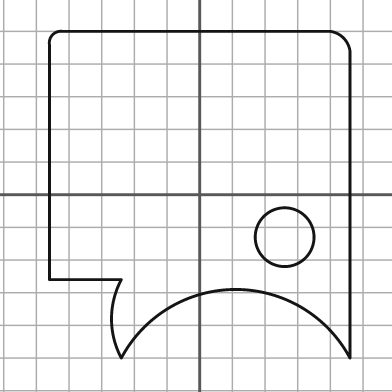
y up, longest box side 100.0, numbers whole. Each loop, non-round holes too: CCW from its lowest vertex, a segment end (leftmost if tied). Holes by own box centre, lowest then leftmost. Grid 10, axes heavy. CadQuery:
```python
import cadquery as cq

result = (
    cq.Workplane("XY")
    .moveTo(-24.0, -50.0)
    .threePointArc((11.0, -29.0), (46.0, -50.0))
    .lineTo(46.0, 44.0)
    .threePointArc((44.0, 48.0), (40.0, 50.0))
    .lineTo(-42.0, 50.0)
    .threePointArc((-45.0, 49.0), (-46.0, 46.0))
    .lineTo(-46.0, -26.0)
    .lineTo(-24.0, -26.0)
    .threePointArc((-27.0, -38.0), (-24.0, -50.0))
    .close()
    .moveTo(26.0, -13.0)
    .circle(9.0)
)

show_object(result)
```